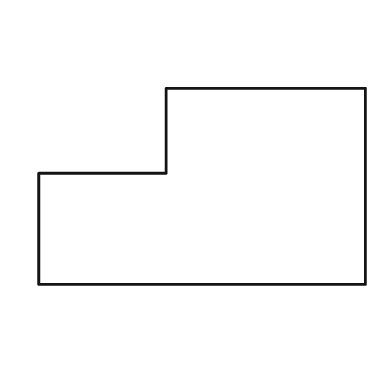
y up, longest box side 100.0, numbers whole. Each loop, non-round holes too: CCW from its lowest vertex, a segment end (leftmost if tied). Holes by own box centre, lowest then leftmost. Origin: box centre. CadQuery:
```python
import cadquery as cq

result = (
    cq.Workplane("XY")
    .moveTo(-50.0, -30.0)
    .lineTo(50.0, -30.0)
    .lineTo(50.0, 30.0)
    .lineTo(-11.0, 30.0)
    .lineTo(-11.0, 4.0)
    .lineTo(-50.0, 4.0)
    .close()
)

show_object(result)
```